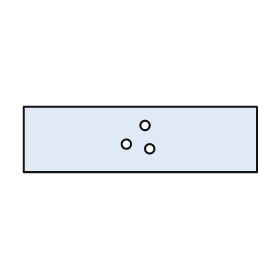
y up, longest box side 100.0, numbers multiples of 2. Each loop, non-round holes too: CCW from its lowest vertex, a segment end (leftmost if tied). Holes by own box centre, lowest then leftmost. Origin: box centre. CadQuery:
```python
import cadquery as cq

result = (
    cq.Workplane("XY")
    .moveTo(-50.0, -14.0)
    .lineTo(50.0, -14.0)
    .lineTo(50.0, 14.0)
    .lineTo(-50.0, 14.0)
    .close()
    .moveTo(4.0, -4.0)
    .circle(2.0)
    .moveTo(-6.0, -2.0)
    .circle(2.0)
    .moveTo(2.0, 6.0)
    .circle(2.0)
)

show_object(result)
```